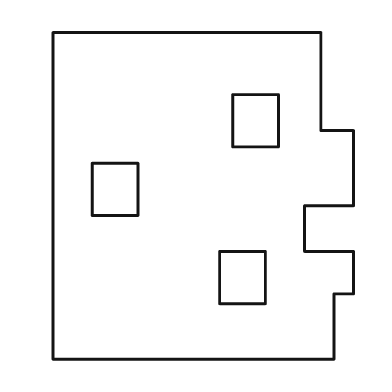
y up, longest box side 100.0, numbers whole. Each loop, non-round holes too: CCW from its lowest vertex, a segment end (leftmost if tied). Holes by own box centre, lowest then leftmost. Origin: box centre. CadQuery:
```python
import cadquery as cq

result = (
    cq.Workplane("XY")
    .moveTo(-46.0, -50.0)
    .lineTo(40.0, -50.0)
    .lineTo(40.0, -30.0)
    .lineTo(46.0, -30.0)
    .lineTo(46.0, -17.0)
    .lineTo(31.0, -17.0)
    .lineTo(31.0, -3.0)
    .lineTo(46.0, -3.0)
    .lineTo(46.0, 20.0)
    .lineTo(36.0, 20.0)
    .lineTo(36.0, 50.0)
    .lineTo(-46.0, 50.0)
    .close()
    .moveTo(5.0, -33.0)
    .lineTo(19.0, -33.0)
    .lineTo(19.0, -17.0)
    .lineTo(5.0, -17.0)
    .close()
    .moveTo(-34.0, -6.0)
    .lineTo(-20.0, -6.0)
    .lineTo(-20.0, 10.0)
    .lineTo(-34.0, 10.0)
    .close()
    .moveTo(9.0, 15.0)
    .lineTo(23.0, 15.0)
    .lineTo(23.0, 31.0)
    .lineTo(9.0, 31.0)
    .close()
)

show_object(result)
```